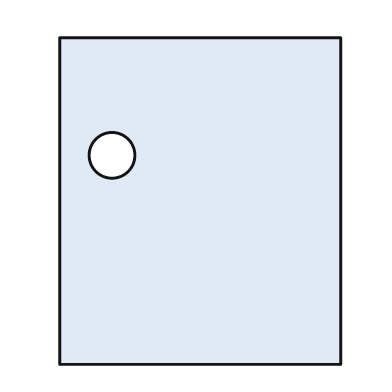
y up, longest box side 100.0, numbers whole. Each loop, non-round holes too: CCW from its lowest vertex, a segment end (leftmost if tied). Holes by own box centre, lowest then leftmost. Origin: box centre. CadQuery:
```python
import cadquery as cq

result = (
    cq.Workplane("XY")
    .moveTo(-43.0, -50.0)
    .lineTo(43.0, -50.0)
    .lineTo(43.0, 50.0)
    .lineTo(-43.0, 50.0)
    .close()
    .moveTo(-27.0, 14.0)
    .circle(7.0)
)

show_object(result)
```